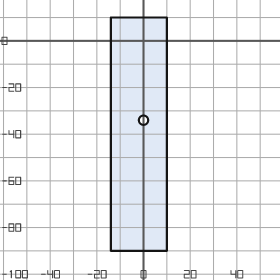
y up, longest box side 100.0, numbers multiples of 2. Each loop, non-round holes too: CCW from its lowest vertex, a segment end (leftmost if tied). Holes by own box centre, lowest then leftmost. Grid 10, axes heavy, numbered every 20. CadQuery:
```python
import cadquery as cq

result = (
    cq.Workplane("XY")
    .moveTo(-14.0, -90.0)
    .lineTo(10.0, -90.0)
    .lineTo(10.0, 10.0)
    .lineTo(-14.0, 10.0)
    .close()
    .moveTo(0.0, -34.0)
    .circle(2.0)
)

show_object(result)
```